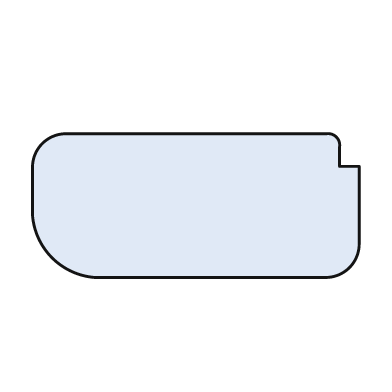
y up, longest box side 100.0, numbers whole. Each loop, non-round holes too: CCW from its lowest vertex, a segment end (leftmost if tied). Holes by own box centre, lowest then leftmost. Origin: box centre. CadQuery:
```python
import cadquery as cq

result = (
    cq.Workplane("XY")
    .moveTo(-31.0, -22.0)
    .lineTo(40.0, -22.0)
    .threePointArc((47.0, -19.0), (50.0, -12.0))
    .lineTo(50.0, 12.0)
    .lineTo(44.0, 12.0)
    .lineTo(44.0, 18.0)
    .threePointArc((43.0, 21.0), (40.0, 22.0))
    .lineTo(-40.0, 22.0)
    .threePointArc((-47.0, 19.0), (-50.0, 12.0))
    .lineTo(-50.0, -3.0)
    .threePointArc((-44.0, -16.0), (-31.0, -22.0))
    .close()
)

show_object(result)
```